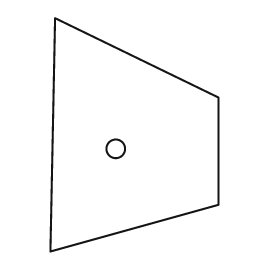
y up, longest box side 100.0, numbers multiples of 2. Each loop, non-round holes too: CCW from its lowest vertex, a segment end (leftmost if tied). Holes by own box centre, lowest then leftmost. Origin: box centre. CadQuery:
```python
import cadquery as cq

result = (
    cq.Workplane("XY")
    .moveTo(-36.0, -50.0)
    .lineTo(36.0, -30.0)
    .lineTo(36.0, 16.0)
    .lineTo(-34.0, 50.0)
    .close()
    .moveTo(-8.0, -6.0)
    .circle(4.0)
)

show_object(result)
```